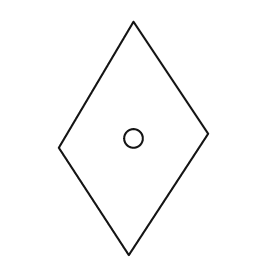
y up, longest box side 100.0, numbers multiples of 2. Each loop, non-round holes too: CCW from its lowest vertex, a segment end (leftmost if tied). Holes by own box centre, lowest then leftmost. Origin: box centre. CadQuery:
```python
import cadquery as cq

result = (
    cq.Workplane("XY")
    .moveTo(-2.0, -50.0)
    .lineTo(32.0, 2.0)
    .lineTo(0.0, 50.0)
    .lineTo(-32.0, -4.0)
    .close()
    .moveTo(0.0, 0.0)
    .circle(4.0)
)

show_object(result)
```